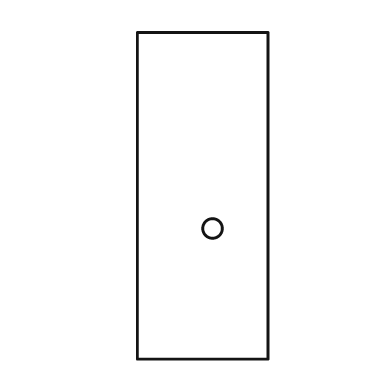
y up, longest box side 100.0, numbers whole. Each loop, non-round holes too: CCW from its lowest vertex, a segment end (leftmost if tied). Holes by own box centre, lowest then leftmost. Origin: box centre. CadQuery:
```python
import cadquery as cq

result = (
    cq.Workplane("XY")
    .moveTo(-20.0, -50.0)
    .lineTo(20.0, -50.0)
    .lineTo(20.0, 50.0)
    .lineTo(-20.0, 50.0)
    .close()
    .moveTo(3.0, -10.0)
    .circle(3.0)
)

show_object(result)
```